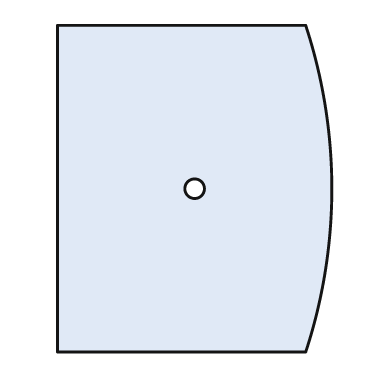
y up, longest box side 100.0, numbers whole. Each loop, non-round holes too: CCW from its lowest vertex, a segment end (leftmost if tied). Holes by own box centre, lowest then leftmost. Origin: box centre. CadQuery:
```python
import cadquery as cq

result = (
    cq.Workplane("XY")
    .moveTo(-42.0, -50.0)
    .lineTo(34.0, -50.0)
    .threePointArc((42.0, 0.0), (34.0, 50.0))
    .lineTo(-42.0, 50.0)
    .close()
    .moveTo(0.0, 0.0)
    .circle(3.0)
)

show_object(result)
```